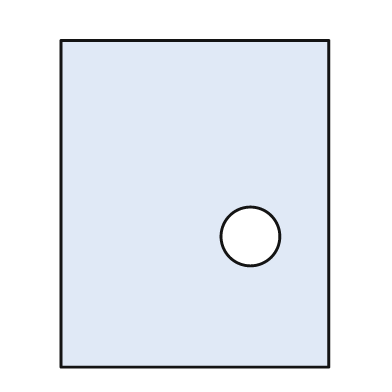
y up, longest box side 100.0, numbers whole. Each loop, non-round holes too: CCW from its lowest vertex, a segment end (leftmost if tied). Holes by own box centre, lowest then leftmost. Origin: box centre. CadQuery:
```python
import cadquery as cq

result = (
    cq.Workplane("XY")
    .moveTo(-41.0, -50.0)
    .lineTo(41.0, -50.0)
    .lineTo(41.0, 50.0)
    .lineTo(-41.0, 50.0)
    .close()
    .moveTo(17.0, -10.0)
    .circle(9.0)
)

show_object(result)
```